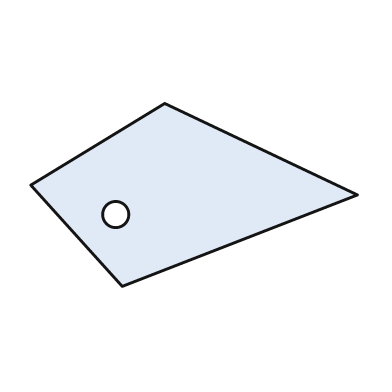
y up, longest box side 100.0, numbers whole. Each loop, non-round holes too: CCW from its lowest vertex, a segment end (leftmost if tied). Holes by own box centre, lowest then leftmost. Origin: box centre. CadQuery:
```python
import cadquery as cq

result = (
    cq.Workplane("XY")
    .moveTo(-22.0, -28.0)
    .lineTo(50.0, 0.0)
    .lineTo(-9.0, 28.0)
    .lineTo(-50.0, 3.0)
    .close()
    .moveTo(-24.0, -6.0)
    .circle(4.0)
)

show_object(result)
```